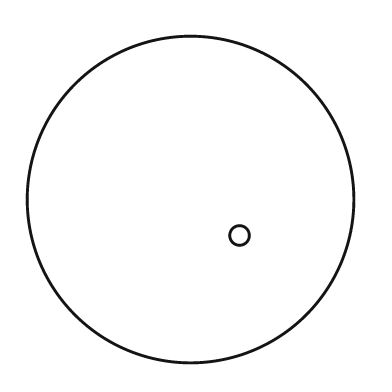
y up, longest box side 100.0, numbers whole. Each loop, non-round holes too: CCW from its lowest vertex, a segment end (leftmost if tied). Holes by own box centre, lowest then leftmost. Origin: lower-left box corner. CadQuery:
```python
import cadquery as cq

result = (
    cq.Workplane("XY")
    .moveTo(50.0, 50.0)
    .circle(50.0)
    .moveTo(65.0, 39.0)
    .circle(3.0)
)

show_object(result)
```